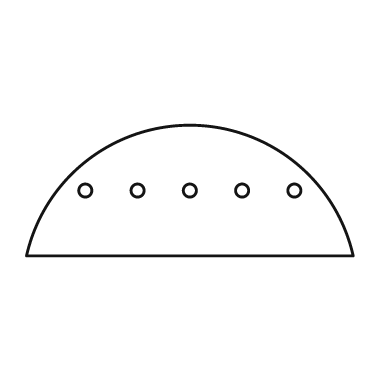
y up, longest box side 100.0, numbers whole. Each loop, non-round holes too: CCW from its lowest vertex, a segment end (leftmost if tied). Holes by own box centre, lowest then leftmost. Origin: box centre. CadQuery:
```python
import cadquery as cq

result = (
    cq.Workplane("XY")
    .moveTo(-50.0, -20.0)
    .lineTo(50.0, -20.0)
    .threePointArc((0.0, 20.0), (-50.0, -20.0))
    .close()
    .moveTo(-32.0, 0.0)
    .circle(2.0)
    .moveTo(-16.0, 0.0)
    .circle(2.0)
    .moveTo(0.0, 0.0)
    .circle(2.0)
    .moveTo(16.0, 0.0)
    .circle(2.0)
    .moveTo(32.0, 0.0)
    .circle(2.0)
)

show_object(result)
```